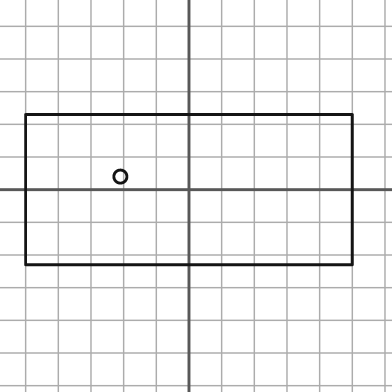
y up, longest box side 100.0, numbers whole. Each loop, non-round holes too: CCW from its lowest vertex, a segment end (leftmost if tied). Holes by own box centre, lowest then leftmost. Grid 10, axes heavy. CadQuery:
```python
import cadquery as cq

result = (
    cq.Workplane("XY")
    .moveTo(-50.0, -23.0)
    .lineTo(50.0, -23.0)
    .lineTo(50.0, 23.0)
    .lineTo(-50.0, 23.0)
    .close()
    .moveTo(-21.0, 4.0)
    .circle(2.0)
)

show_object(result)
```